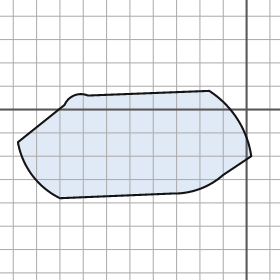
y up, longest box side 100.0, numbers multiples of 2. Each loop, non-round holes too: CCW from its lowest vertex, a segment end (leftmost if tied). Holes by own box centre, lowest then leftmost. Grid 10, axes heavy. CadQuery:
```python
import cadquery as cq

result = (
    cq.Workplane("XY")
    .moveTo(-80.0, -38.0)
    .lineTo(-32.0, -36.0)
    .threePointArc((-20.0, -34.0), (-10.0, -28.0))
    .lineTo(2.0, -20.0)
    .threePointArc((-4.0, -4.0), (-16.0, 8.0))
    .lineTo(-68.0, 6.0)
    .threePointArc((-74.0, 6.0), (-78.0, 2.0))
    .lineTo(-98.0, -14.0)
    .threePointArc((-92.0, -28.0), (-80.0, -38.0))
    .close()
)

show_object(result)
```